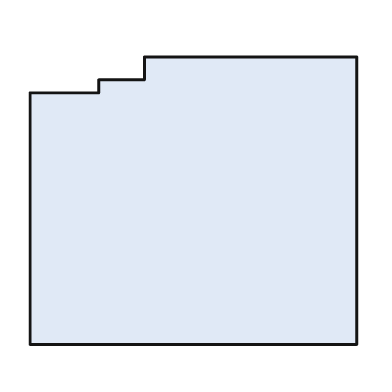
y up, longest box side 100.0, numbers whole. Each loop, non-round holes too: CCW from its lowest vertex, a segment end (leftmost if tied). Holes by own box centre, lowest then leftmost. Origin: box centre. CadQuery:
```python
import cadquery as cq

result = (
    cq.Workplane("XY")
    .moveTo(-50.0, -44.0)
    .lineTo(50.0, -44.0)
    .lineTo(50.0, 44.0)
    .lineTo(-15.0, 44.0)
    .lineTo(-15.0, 37.0)
    .lineTo(-29.0, 37.0)
    .lineTo(-29.0, 33.0)
    .lineTo(-50.0, 33.0)
    .close()
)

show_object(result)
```